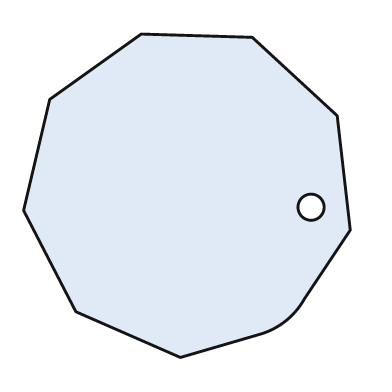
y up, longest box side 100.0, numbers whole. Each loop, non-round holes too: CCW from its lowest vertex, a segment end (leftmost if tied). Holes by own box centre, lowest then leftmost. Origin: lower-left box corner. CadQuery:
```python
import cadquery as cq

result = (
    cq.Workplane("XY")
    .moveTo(48.0, 0.0)
    .lineTo(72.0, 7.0)
    .threePointArc((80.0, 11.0), (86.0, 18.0))
    .lineTo(100.0, 39.0)
    .lineTo(96.0, 74.0)
    .lineTo(70.0, 98.0)
    .lineTo(36.0, 99.0)
    .lineTo(8.0, 79.0)
    .lineTo(0.0, 45.0)
    .lineTo(16.0, 14.0)
    .close()
    .moveTo(88.0, 46.0)
    .circle(4.0)
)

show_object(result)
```